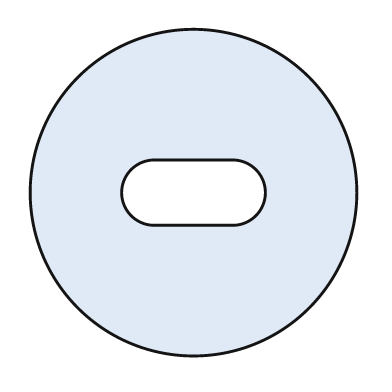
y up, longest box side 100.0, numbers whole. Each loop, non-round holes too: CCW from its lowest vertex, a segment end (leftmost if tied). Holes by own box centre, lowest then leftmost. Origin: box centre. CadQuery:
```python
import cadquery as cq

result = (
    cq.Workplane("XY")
    .moveTo(0.0, 0.0)
    .circle(50.0)
    .moveTo(-12.0, -10.0)
    .lineTo(12.0, -10.0)
    .threePointArc((22.0, 0.0), (12.0, 10.0))
    .lineTo(-12.0, 10.0)
    .threePointArc((-22.0, 0.0), (-12.0, -10.0))
    .close()
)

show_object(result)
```